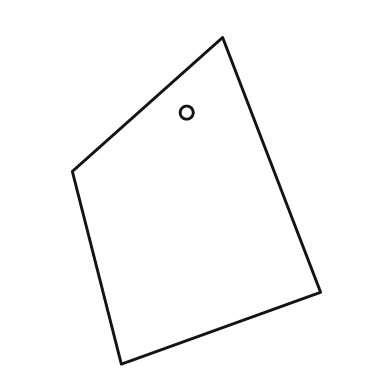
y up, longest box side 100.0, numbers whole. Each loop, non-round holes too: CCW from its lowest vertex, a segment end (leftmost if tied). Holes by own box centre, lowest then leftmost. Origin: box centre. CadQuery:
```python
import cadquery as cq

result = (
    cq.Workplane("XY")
    .moveTo(-23.0, -50.0)
    .lineTo(38.0, -28.0)
    .lineTo(8.0, 50.0)
    .lineTo(-38.0, 9.0)
    .close()
    .moveTo(-3.0, 27.0)
    .circle(2.0)
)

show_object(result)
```